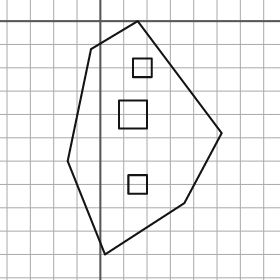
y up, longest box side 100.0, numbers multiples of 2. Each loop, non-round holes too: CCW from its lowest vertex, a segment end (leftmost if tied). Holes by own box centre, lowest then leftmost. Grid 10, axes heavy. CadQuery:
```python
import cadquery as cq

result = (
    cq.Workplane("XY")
    .moveTo(2.0, -100.0)
    .lineTo(36.0, -78.0)
    .lineTo(52.0, -48.0)
    .lineTo(16.0, 0.0)
    .lineTo(-4.0, -12.0)
    .lineTo(-14.0, -60.0)
    .close()
    .moveTo(12.0, -74.0)
    .lineTo(20.0, -74.0)
    .lineTo(20.0, -66.0)
    .lineTo(12.0, -66.0)
    .close()
    .moveTo(8.0, -46.0)
    .lineTo(20.0, -46.0)
    .lineTo(20.0, -34.0)
    .lineTo(8.0, -34.0)
    .close()
    .moveTo(14.0, -24.0)
    .lineTo(22.0, -24.0)
    .lineTo(22.0, -16.0)
    .lineTo(14.0, -16.0)
    .close()
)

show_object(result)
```